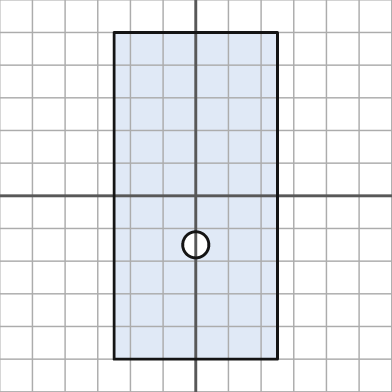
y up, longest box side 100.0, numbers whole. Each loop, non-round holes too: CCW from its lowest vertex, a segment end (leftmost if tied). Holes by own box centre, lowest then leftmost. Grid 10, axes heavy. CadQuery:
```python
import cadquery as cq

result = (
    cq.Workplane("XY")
    .moveTo(-25.0, -50.0)
    .lineTo(25.0, -50.0)
    .lineTo(25.0, 50.0)
    .lineTo(-25.0, 50.0)
    .close()
    .moveTo(0.0, -15.0)
    .circle(4.0)
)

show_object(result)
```